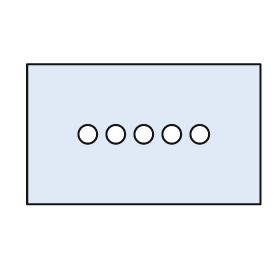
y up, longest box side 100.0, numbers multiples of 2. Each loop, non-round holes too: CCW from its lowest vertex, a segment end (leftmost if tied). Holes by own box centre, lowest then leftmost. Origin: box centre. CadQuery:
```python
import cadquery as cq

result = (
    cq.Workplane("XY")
    .moveTo(-50.0, -30.0)
    .lineTo(50.0, -30.0)
    .lineTo(50.0, 30.0)
    .lineTo(-50.0, 30.0)
    .close()
    .moveTo(-24.0, 0.0)
    .circle(4.0)
    .moveTo(-12.0, 0.0)
    .circle(4.0)
    .moveTo(0.0, 0.0)
    .circle(4.0)
    .moveTo(12.0, 0.0)
    .circle(4.0)
    .moveTo(24.0, 0.0)
    .circle(4.0)
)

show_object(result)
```